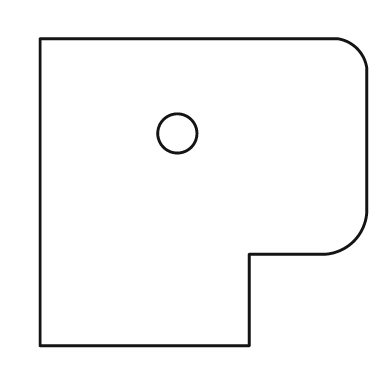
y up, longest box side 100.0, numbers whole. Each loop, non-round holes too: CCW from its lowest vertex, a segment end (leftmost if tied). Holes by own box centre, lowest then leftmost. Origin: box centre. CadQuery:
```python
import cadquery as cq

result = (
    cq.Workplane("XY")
    .moveTo(-50.0, -47.0)
    .lineTo(14.0, -47.0)
    .lineTo(14.0, -19.0)
    .lineTo(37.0, -19.0)
    .threePointArc((46.0, -15.0), (50.0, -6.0))
    .lineTo(50.0, 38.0)
    .threePointArc((47.0, 44.0), (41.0, 47.0))
    .lineTo(-50.0, 47.0)
    .close()
    .moveTo(-8.0, 18.0)
    .circle(6.0)
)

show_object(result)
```